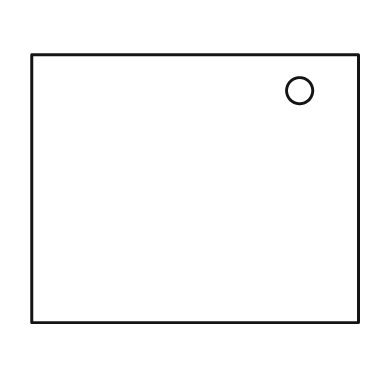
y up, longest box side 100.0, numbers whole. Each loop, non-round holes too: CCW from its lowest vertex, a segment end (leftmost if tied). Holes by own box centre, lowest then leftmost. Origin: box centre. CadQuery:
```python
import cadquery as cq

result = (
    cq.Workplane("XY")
    .moveTo(-50.0, -41.0)
    .lineTo(50.0, -41.0)
    .lineTo(50.0, 41.0)
    .lineTo(-50.0, 41.0)
    .close()
    .moveTo(32.0, 30.0)
    .circle(4.0)
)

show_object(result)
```